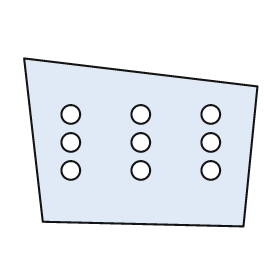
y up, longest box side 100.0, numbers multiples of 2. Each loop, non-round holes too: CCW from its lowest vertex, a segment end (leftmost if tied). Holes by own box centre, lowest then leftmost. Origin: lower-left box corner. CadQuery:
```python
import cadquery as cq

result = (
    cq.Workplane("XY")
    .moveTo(94.0, 0.0)
    .lineTo(100.0, 60.0)
    .lineTo(0.0, 72.0)
    .lineTo(8.0, 2.0)
    .close()
    .moveTo(20.0, 24.0)
    .circle(4.0)
    .moveTo(50.0, 24.0)
    .circle(4.0)
    .moveTo(80.0, 24.0)
    .circle(4.0)
    .moveTo(20.0, 36.0)
    .circle(4.0)
    .moveTo(50.0, 36.0)
    .circle(4.0)
    .moveTo(80.0, 36.0)
    .circle(4.0)
    .moveTo(20.0, 48.0)
    .circle(4.0)
    .moveTo(50.0, 48.0)
    .circle(4.0)
    .moveTo(80.0, 48.0)
    .circle(4.0)
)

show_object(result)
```